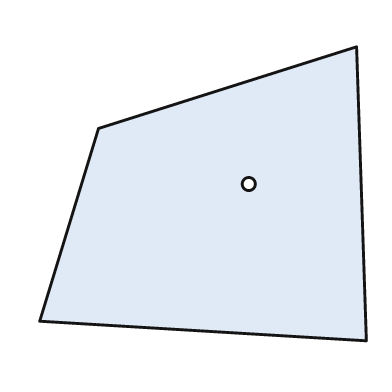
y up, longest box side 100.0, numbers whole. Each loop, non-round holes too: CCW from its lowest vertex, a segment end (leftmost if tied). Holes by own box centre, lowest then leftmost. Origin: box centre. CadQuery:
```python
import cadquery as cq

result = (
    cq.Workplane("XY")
    .moveTo(50.0, -45.0)
    .lineTo(47.0, 45.0)
    .lineTo(-32.0, 20.0)
    .lineTo(-50.0, -39.0)
    .close()
    .moveTo(14.0, 3.0)
    .circle(2.0)
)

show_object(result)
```